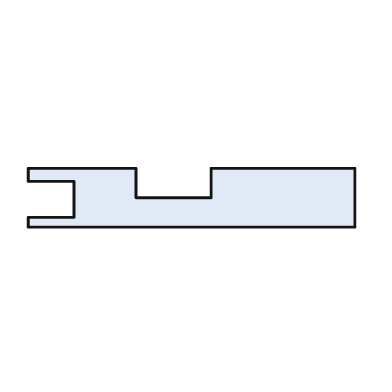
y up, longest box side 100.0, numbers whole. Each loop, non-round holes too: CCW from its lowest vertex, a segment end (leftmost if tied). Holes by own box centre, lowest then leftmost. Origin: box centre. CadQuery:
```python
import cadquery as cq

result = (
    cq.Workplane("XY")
    .moveTo(-50.0, -9.0)
    .lineTo(50.0, -9.0)
    .lineTo(50.0, 9.0)
    .lineTo(6.0, 9.0)
    .lineTo(6.0, 0.0)
    .lineTo(-17.0, 0.0)
    .lineTo(-17.0, 9.0)
    .lineTo(-50.0, 9.0)
    .lineTo(-50.0, 5.0)
    .lineTo(-36.0, 5.0)
    .lineTo(-36.0, -6.0)
    .lineTo(-50.0, -6.0)
    .close()
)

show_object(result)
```